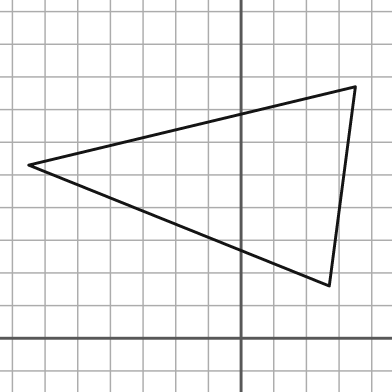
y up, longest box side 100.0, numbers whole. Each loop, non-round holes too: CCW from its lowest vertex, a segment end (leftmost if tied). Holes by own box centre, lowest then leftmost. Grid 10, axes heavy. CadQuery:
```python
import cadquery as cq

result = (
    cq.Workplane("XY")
    .moveTo(27.0, 16.0)
    .lineTo(35.0, 77.0)
    .lineTo(-65.0, 53.0)
    .close()
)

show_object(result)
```